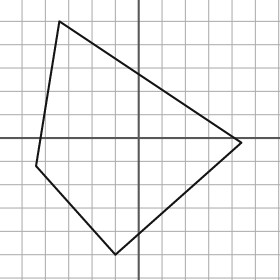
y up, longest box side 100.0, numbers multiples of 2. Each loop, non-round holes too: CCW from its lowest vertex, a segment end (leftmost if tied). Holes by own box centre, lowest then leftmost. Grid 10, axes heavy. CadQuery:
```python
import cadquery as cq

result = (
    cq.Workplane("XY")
    .moveTo(-10.0, -50.0)
    .lineTo(44.0, -2.0)
    .lineTo(-34.0, 50.0)
    .lineTo(-44.0, -12.0)
    .close()
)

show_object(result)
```